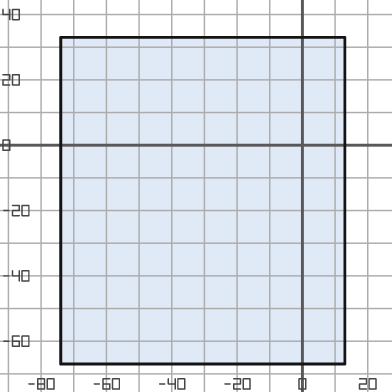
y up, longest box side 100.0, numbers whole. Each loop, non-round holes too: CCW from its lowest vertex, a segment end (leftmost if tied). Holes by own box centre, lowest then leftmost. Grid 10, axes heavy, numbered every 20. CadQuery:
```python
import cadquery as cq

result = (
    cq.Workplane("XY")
    .moveTo(-74.0, -67.0)
    .lineTo(13.0, -67.0)
    .lineTo(13.0, 33.0)
    .lineTo(-74.0, 33.0)
    .close()
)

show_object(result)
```